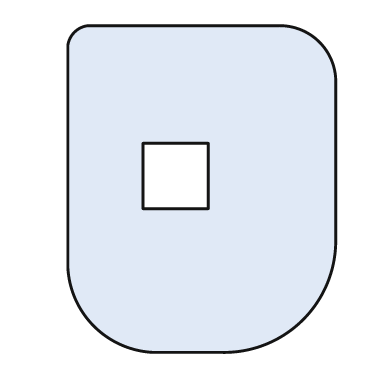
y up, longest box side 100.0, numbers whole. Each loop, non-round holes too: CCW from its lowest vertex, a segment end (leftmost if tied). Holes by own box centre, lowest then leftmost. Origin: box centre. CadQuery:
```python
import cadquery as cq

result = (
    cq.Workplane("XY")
    .moveTo(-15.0, -50.0)
    .lineTo(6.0, -50.0)
    .threePointArc((31.0, -40.0), (41.0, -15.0))
    .lineTo(41.0, 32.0)
    .threePointArc((36.0, 45.0), (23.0, 50.0))
    .lineTo(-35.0, 50.0)
    .threePointArc((-39.0, 48.0), (-41.0, 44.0))
    .lineTo(-41.0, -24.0)
    .threePointArc((-33.0, -42.0), (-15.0, -50.0))
    .close()
    .moveTo(-18.0, -6.0)
    .lineTo(2.0, -6.0)
    .lineTo(2.0, 14.0)
    .lineTo(-18.0, 14.0)
    .close()
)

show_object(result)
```